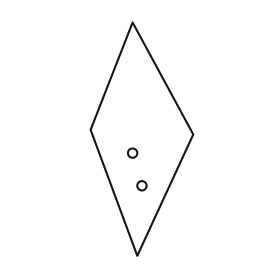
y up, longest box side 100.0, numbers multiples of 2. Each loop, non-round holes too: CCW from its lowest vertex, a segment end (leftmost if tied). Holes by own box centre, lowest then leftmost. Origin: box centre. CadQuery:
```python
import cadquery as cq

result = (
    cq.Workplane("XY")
    .moveTo(-2.0, -50.0)
    .lineTo(22.0, 2.0)
    .lineTo(-4.0, 50.0)
    .lineTo(-22.0, 4.0)
    .close()
    .moveTo(0.0, -20.0)
    .circle(2.0)
    .moveTo(-4.0, -6.0)
    .circle(2.0)
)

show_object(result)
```